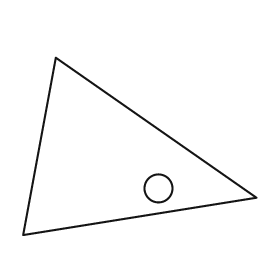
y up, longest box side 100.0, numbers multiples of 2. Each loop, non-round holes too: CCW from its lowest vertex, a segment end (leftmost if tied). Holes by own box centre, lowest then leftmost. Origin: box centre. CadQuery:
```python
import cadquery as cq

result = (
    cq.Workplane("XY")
    .moveTo(-50.0, -38.0)
    .lineTo(50.0, -22.0)
    .lineTo(-36.0, 38.0)
    .close()
    .moveTo(8.0, -18.0)
    .circle(6.0)
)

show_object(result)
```